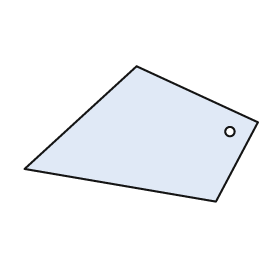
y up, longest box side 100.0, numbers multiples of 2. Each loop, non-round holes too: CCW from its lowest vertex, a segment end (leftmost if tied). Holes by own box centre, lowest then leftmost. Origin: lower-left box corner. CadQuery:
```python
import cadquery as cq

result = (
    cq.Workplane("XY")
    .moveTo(82.0, 0.0)
    .lineTo(100.0, 34.0)
    .lineTo(48.0, 58.0)
    .lineTo(0.0, 14.0)
    .close()
    .moveTo(88.0, 30.0)
    .circle(2.0)
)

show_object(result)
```